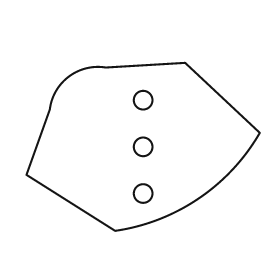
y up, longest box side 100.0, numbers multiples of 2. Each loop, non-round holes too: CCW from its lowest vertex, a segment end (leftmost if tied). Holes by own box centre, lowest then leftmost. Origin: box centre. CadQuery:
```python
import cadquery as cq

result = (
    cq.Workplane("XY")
    .moveTo(-12.0, -36.0)
    .threePointArc((24.0, -22.0), (50.0, 6.0))
    .lineTo(18.0, 36.0)
    .lineTo(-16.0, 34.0)
    .threePointArc((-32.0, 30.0), (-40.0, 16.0))
    .lineTo(-50.0, -12.0)
    .close()
    .moveTo(0.0, -20.0)
    .circle(4.0)
    .moveTo(0.0, 0.0)
    .circle(4.0)
    .moveTo(0.0, 20.0)
    .circle(4.0)
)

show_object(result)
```